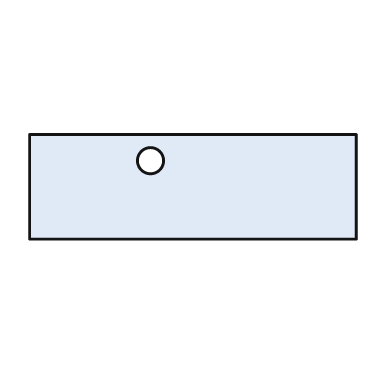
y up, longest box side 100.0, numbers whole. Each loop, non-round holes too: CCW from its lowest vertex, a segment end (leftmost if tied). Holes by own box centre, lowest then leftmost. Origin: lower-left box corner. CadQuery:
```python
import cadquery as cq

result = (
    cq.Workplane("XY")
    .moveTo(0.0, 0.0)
    .lineTo(100.0, 0.0)
    .lineTo(100.0, 32.0)
    .lineTo(0.0, 32.0)
    .close()
    .moveTo(37.0, 24.0)
    .circle(4.0)
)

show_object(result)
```